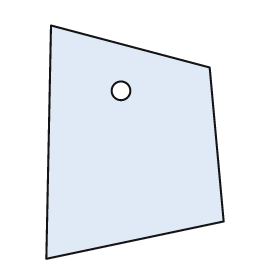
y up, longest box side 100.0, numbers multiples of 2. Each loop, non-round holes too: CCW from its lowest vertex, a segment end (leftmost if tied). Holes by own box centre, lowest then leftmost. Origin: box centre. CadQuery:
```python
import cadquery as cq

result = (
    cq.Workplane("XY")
    .moveTo(-38.0, -50.0)
    .lineTo(38.0, -34.0)
    .lineTo(32.0, 32.0)
    .lineTo(-36.0, 50.0)
    .close()
    .moveTo(-6.0, 22.0)
    .circle(4.0)
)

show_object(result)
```